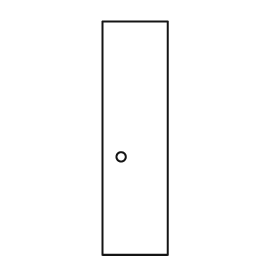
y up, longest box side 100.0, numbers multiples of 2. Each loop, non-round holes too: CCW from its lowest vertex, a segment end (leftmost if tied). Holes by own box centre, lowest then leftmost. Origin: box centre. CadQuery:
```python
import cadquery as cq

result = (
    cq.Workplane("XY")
    .moveTo(-14.0, -50.0)
    .lineTo(14.0, -50.0)
    .lineTo(14.0, 50.0)
    .lineTo(-14.0, 50.0)
    .close()
    .moveTo(-6.0, -8.0)
    .circle(2.0)
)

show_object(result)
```